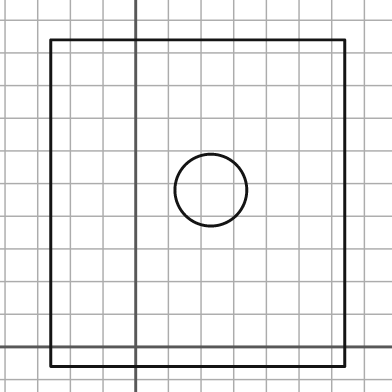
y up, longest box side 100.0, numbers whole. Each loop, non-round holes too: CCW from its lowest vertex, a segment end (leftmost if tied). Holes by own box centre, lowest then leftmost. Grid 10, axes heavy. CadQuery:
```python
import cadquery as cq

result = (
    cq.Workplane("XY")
    .moveTo(-26.0, -6.0)
    .lineTo(64.0, -6.0)
    .lineTo(64.0, 94.0)
    .lineTo(-26.0, 94.0)
    .close()
    .moveTo(23.0, 48.0)
    .circle(11.0)
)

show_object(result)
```